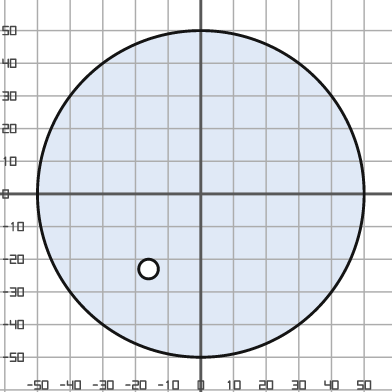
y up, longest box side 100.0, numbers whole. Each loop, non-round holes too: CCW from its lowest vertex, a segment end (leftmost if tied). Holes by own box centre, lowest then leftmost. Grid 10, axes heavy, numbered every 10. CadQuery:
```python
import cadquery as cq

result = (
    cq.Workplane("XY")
    .moveTo(0.0, 0.0)
    .circle(50.0)
    .moveTo(-16.0, -23.0)
    .circle(3.0)
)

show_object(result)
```